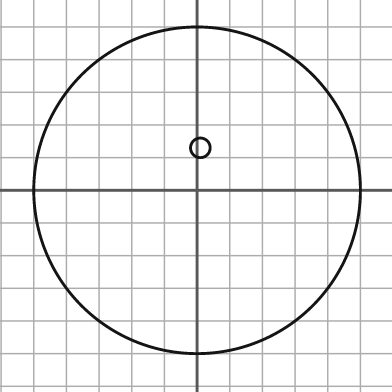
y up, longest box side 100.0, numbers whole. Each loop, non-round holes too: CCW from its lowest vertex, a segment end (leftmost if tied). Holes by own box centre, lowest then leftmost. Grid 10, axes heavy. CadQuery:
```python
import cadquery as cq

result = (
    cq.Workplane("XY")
    .moveTo(0.0, 0.0)
    .circle(50.0)
    .moveTo(1.0, 13.0)
    .circle(3.0)
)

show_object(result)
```